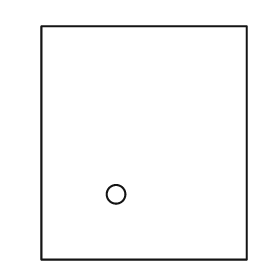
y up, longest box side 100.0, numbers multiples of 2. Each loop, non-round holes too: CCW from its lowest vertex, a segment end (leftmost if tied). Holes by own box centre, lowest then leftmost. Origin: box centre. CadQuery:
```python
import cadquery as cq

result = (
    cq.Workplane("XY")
    .moveTo(-44.0, -50.0)
    .lineTo(44.0, -50.0)
    .lineTo(44.0, 50.0)
    .lineTo(-44.0, 50.0)
    .close()
    .moveTo(-12.0, -22.0)
    .circle(4.0)
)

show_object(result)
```